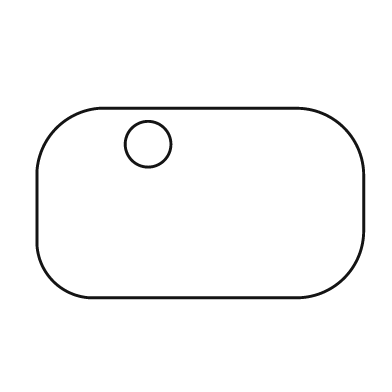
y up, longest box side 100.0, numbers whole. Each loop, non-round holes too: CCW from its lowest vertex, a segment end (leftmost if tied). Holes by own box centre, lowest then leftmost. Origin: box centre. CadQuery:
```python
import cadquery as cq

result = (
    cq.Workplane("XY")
    .moveTo(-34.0, -29.0)
    .lineTo(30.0, -29.0)
    .threePointArc((44.0, -23.0), (50.0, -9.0))
    .lineTo(50.0, 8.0)
    .threePointArc((44.0, 23.0), (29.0, 29.0))
    .lineTo(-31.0, 29.0)
    .threePointArc((-44.0, 23.0), (-50.0, 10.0))
    .lineTo(-50.0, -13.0)
    .threePointArc((-45.0, -24.0), (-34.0, -29.0))
    .close()
    .moveTo(-16.0, 18.0)
    .circle(7.0)
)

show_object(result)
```